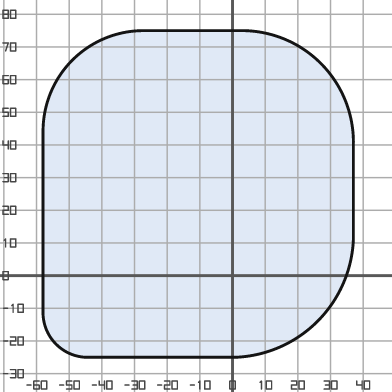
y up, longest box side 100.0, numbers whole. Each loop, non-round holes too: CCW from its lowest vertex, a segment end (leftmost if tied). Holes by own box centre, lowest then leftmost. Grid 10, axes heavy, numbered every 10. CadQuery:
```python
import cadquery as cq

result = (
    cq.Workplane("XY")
    .moveTo(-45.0, -25.0)
    .lineTo(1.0, -25.0)
    .threePointArc((26.0, -14.0), (37.0, 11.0))
    .lineTo(37.0, 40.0)
    .threePointArc((27.0, 65.0), (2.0, 75.0))
    .lineTo(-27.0, 75.0)
    .threePointArc((-49.0, 66.0), (-58.0, 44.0))
    .lineTo(-58.0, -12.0)
    .threePointArc((-54.0, -21.0), (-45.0, -25.0))
    .close()
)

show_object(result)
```